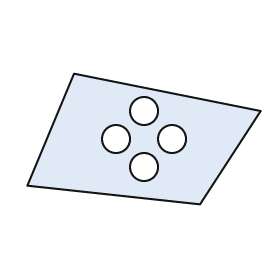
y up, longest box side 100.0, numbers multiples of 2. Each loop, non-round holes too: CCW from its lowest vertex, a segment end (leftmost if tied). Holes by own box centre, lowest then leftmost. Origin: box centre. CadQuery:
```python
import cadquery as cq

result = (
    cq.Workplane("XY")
    .moveTo(24.0, -28.0)
    .lineTo(50.0, 12.0)
    .lineTo(-30.0, 28.0)
    .lineTo(-50.0, -20.0)
    .close()
    .moveTo(0.0, -12.0)
    .circle(6.0)
    .moveTo(-12.0, 0.0)
    .circle(6.0)
    .moveTo(12.0, 0.0)
    .circle(6.0)
    .moveTo(0.0, 12.0)
    .circle(6.0)
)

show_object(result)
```